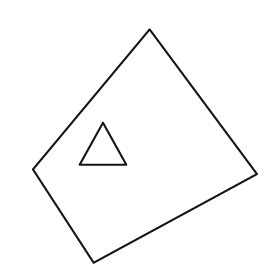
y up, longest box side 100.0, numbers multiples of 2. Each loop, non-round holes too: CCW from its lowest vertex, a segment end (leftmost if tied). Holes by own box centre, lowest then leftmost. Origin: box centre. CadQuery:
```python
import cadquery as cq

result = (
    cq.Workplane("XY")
    .moveTo(-22.0, -50.0)
    .lineTo(48.0, -12.0)
    .lineTo(2.0, 50.0)
    .lineTo(-48.0, -10.0)
    .close()
    .moveTo(-28.0, -8.0)
    .lineTo(-8.0, -8.0)
    .lineTo(-18.0, 10.0)
    .close()
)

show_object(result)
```